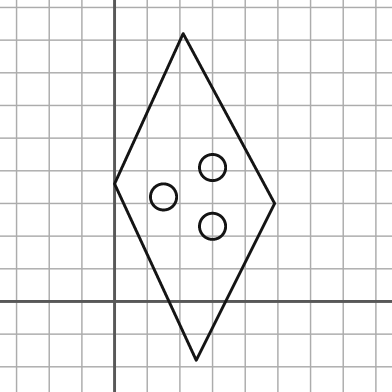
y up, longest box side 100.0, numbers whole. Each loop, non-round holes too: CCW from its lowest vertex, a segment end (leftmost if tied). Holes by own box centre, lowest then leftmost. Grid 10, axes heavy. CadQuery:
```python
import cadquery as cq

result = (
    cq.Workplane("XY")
    .moveTo(25.0, -18.0)
    .lineTo(49.0, 30.0)
    .lineTo(21.0, 82.0)
    .lineTo(0.0, 36.0)
    .close()
    .moveTo(30.0, 23.0)
    .circle(4.0)
    .moveTo(15.0, 32.0)
    .circle(4.0)
    .moveTo(30.0, 41.0)
    .circle(4.0)
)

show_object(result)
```